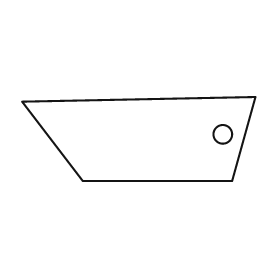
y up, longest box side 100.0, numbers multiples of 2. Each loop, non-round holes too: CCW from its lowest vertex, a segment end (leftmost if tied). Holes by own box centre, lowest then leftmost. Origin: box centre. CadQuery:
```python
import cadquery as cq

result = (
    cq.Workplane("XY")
    .moveTo(-24.0, -18.0)
    .lineTo(40.0, -18.0)
    .lineTo(50.0, 18.0)
    .lineTo(-50.0, 16.0)
    .close()
    .moveTo(36.0, 2.0)
    .circle(4.0)
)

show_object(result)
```